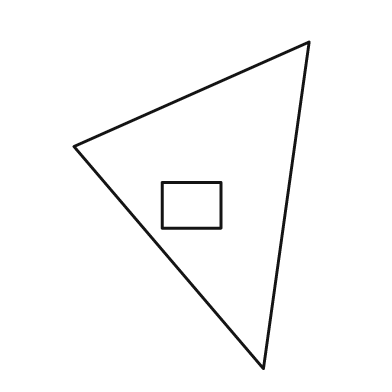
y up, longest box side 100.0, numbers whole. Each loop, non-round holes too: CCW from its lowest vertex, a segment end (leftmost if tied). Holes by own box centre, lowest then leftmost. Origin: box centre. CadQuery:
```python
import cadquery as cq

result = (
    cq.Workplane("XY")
    .moveTo(22.0, -50.0)
    .lineTo(36.0, 50.0)
    .lineTo(-36.0, 18.0)
    .close()
    .moveTo(-9.0, -7.0)
    .lineTo(9.0, -7.0)
    .lineTo(9.0, 7.0)
    .lineTo(-9.0, 7.0)
    .close()
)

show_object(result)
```